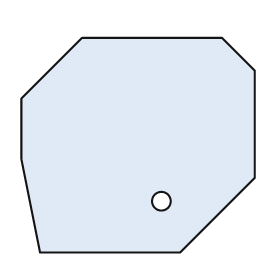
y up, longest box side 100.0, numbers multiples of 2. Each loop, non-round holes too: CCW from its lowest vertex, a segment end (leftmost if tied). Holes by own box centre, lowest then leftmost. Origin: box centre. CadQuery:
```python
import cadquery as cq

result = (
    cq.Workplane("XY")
    .moveTo(-42.0, -46.0)
    .lineTo(18.0, -46.0)
    .lineTo(50.0, -14.0)
    .lineTo(50.0, 32.0)
    .lineTo(36.0, 46.0)
    .lineTo(-24.0, 46.0)
    .lineTo(-50.0, 20.0)
    .lineTo(-50.0, -6.0)
    .close()
    .moveTo(10.0, -24.0)
    .circle(4.0)
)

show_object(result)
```